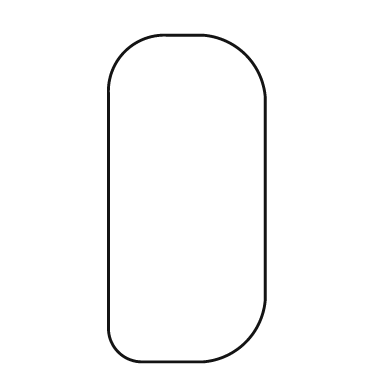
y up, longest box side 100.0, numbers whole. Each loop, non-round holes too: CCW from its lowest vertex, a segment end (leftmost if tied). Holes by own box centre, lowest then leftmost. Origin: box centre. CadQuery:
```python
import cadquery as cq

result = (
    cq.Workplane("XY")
    .moveTo(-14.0, -50.0)
    .lineTo(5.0, -50.0)
    .threePointArc((18.0, -44.0), (24.0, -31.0))
    .lineTo(24.0, 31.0)
    .threePointArc((18.0, 44.0), (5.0, 50.0))
    .lineTo(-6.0, 50.0)
    .threePointArc((-19.0, 45.0), (-24.0, 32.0))
    .lineTo(-24.0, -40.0)
    .threePointArc((-21.0, -47.0), (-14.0, -50.0))
    .close()
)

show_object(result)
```